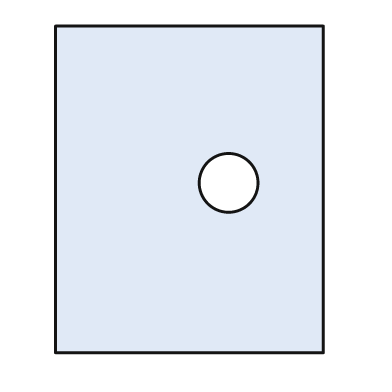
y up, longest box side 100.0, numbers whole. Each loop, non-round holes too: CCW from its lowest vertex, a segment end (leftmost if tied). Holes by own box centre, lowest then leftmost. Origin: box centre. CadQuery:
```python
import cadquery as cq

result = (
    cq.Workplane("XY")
    .moveTo(-41.0, -50.0)
    .lineTo(41.0, -50.0)
    .lineTo(41.0, 50.0)
    .lineTo(-41.0, 50.0)
    .close()
    .moveTo(12.0, 2.0)
    .circle(9.0)
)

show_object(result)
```